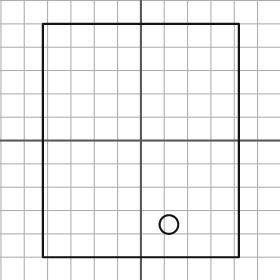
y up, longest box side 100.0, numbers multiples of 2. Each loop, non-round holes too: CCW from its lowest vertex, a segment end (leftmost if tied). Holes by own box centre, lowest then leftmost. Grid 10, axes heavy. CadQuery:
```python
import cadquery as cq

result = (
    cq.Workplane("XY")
    .moveTo(-42.0, -50.0)
    .lineTo(42.0, -50.0)
    .lineTo(42.0, 50.0)
    .lineTo(-42.0, 50.0)
    .close()
    .moveTo(12.0, -36.0)
    .circle(4.0)
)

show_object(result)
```